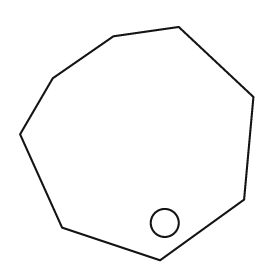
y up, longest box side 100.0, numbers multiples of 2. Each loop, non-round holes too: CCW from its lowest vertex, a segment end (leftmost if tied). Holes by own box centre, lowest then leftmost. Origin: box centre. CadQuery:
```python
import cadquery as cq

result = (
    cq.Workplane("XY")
    .moveTo(10.0, -50.0)
    .lineTo(46.0, -24.0)
    .lineTo(50.0, 20.0)
    .lineTo(18.0, 50.0)
    .lineTo(-10.0, 46.0)
    .lineTo(-36.0, 28.0)
    .lineTo(-50.0, 4.0)
    .lineTo(-32.0, -36.0)
    .close()
    .moveTo(12.0, -34.0)
    .circle(6.0)
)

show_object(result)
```